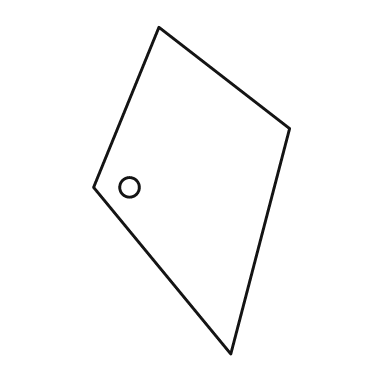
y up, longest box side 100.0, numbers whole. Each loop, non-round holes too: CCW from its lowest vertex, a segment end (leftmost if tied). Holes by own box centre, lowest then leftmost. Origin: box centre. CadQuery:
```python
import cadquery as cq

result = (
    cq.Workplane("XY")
    .moveTo(12.0, -50.0)
    .lineTo(30.0, 19.0)
    .lineTo(-10.0, 50.0)
    .lineTo(-30.0, 1.0)
    .close()
    .moveTo(-19.0, 1.0)
    .circle(3.0)
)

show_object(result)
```